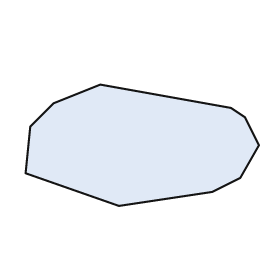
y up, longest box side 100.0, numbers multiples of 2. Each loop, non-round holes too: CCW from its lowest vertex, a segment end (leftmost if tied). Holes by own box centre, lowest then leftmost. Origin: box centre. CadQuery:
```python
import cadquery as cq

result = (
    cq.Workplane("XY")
    .moveTo(-10.0, -26.0)
    .lineTo(30.0, -20.0)
    .lineTo(42.0, -14.0)
    .lineTo(50.0, 0.0)
    .lineTo(44.0, 12.0)
    .lineTo(38.0, 16.0)
    .lineTo(-18.0, 26.0)
    .lineTo(-38.0, 18.0)
    .lineTo(-48.0, 8.0)
    .lineTo(-50.0, -12.0)
    .close()
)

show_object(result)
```